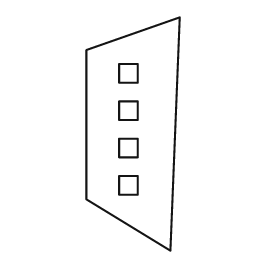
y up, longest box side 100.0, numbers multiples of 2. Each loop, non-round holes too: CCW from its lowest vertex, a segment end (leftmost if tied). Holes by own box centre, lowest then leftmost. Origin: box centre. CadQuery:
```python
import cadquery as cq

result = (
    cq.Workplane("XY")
    .moveTo(16.0, -50.0)
    .lineTo(20.0, 50.0)
    .lineTo(-20.0, 36.0)
    .lineTo(-20.0, -28.0)
    .close()
    .moveTo(-6.0, -26.0)
    .lineTo(2.0, -26.0)
    .lineTo(2.0, -18.0)
    .lineTo(-6.0, -18.0)
    .close()
    .moveTo(-6.0, -10.0)
    .lineTo(2.0, -10.0)
    .lineTo(2.0, -2.0)
    .lineTo(-6.0, -2.0)
    .close()
    .moveTo(-6.0, 6.0)
    .lineTo(2.0, 6.0)
    .lineTo(2.0, 14.0)
    .lineTo(-6.0, 14.0)
    .close()
    .moveTo(-6.0, 22.0)
    .lineTo(2.0, 22.0)
    .lineTo(2.0, 30.0)
    .lineTo(-6.0, 30.0)
    .close()
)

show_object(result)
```